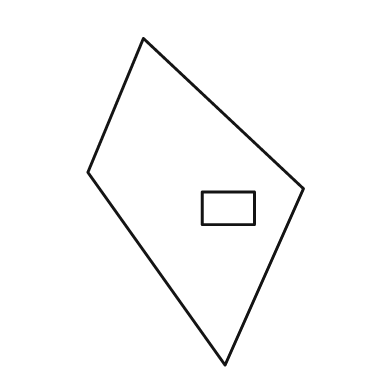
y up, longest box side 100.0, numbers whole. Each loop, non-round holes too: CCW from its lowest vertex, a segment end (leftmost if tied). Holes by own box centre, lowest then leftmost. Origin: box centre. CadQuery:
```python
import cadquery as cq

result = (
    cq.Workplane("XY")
    .moveTo(9.0, -50.0)
    .lineTo(33.0, 4.0)
    .lineTo(-16.0, 50.0)
    .lineTo(-33.0, 9.0)
    .close()
    .moveTo(2.0, -7.0)
    .lineTo(18.0, -7.0)
    .lineTo(18.0, 3.0)
    .lineTo(2.0, 3.0)
    .close()
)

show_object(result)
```